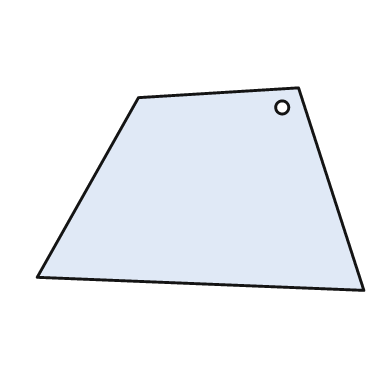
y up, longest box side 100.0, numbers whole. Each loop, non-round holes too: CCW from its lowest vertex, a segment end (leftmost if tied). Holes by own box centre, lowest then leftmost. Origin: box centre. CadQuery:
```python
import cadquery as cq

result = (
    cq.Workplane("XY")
    .moveTo(50.0, -31.0)
    .lineTo(30.0, 31.0)
    .lineTo(-19.0, 28.0)
    .lineTo(-50.0, -27.0)
    .close()
    .moveTo(25.0, 25.0)
    .circle(2.0)
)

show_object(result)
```